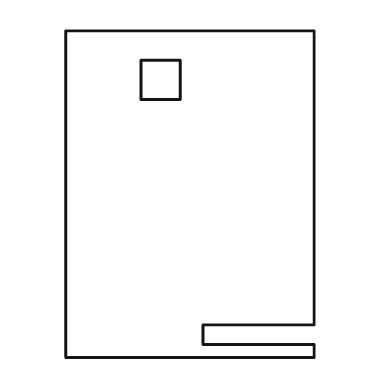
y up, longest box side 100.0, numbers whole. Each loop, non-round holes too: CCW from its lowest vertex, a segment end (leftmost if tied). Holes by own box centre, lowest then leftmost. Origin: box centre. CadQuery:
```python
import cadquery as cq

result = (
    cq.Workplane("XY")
    .moveTo(-38.0, -50.0)
    .lineTo(38.0, -50.0)
    .lineTo(38.0, -46.0)
    .lineTo(4.0, -46.0)
    .lineTo(4.0, -40.0)
    .lineTo(38.0, -40.0)
    .lineTo(38.0, 50.0)
    .lineTo(-38.0, 50.0)
    .close()
    .moveTo(-15.0, 29.0)
    .lineTo(-3.0, 29.0)
    .lineTo(-3.0, 41.0)
    .lineTo(-15.0, 41.0)
    .close()
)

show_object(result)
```